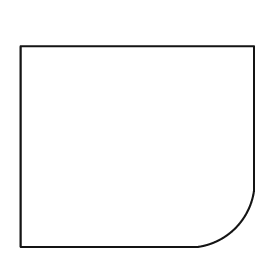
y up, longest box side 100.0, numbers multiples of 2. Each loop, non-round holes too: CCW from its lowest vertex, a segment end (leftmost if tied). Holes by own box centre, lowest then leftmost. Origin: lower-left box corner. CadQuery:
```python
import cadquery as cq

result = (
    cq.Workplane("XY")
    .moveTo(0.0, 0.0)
    .lineTo(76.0, 0.0)
    .threePointArc((92.0, 8.0), (100.0, 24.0))
    .lineTo(100.0, 86.0)
    .lineTo(0.0, 86.0)
    .close()
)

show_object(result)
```